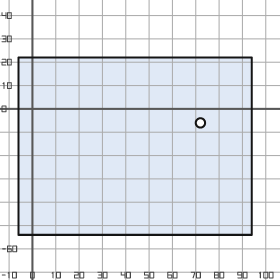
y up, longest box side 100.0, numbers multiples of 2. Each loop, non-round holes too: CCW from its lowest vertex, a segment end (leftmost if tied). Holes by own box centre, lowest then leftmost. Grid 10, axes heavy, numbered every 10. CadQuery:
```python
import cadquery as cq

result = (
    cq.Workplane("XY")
    .moveTo(-6.0, -54.0)
    .lineTo(94.0, -54.0)
    .lineTo(94.0, 22.0)
    .lineTo(-6.0, 22.0)
    .close()
    .moveTo(72.0, -6.0)
    .circle(2.0)
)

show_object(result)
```